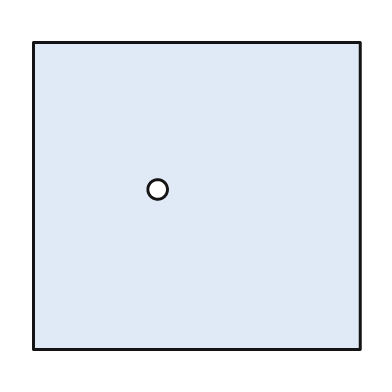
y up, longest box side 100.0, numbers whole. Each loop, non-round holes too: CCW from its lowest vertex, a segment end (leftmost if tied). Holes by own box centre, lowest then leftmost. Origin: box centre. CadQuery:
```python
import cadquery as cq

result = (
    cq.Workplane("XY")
    .moveTo(-50.0, -47.0)
    .lineTo(50.0, -47.0)
    .lineTo(50.0, 47.0)
    .lineTo(-50.0, 47.0)
    .close()
    .moveTo(-12.0, 2.0)
    .circle(3.0)
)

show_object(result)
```